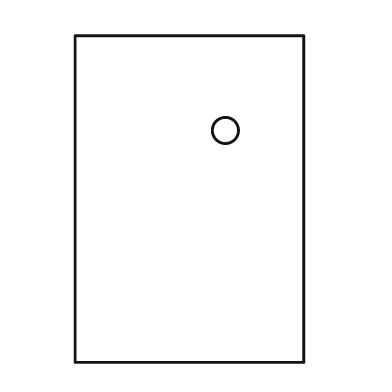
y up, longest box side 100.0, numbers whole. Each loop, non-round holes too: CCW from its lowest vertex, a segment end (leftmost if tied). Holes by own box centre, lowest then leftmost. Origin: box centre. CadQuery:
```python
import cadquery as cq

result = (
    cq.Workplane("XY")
    .moveTo(-35.0, -50.0)
    .lineTo(35.0, -50.0)
    .lineTo(35.0, 50.0)
    .lineTo(-35.0, 50.0)
    .close()
    .moveTo(11.0, 21.0)
    .circle(4.0)
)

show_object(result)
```